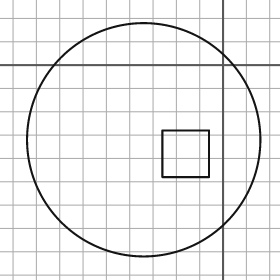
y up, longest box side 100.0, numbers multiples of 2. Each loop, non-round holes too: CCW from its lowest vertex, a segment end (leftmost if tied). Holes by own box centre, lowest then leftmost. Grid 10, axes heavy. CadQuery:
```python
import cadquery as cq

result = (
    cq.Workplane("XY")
    .moveTo(-34.0, -32.0)
    .circle(50.0)
    .moveTo(-26.0, -48.0)
    .lineTo(-6.0, -48.0)
    .lineTo(-6.0, -28.0)
    .lineTo(-26.0, -28.0)
    .close()
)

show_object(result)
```